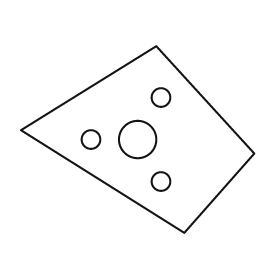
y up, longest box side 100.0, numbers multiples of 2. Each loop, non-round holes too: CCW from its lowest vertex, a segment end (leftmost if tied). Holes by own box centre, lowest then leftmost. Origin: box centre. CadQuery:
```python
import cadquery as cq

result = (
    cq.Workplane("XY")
    .moveTo(20.0, -40.0)
    .lineTo(50.0, -6.0)
    .lineTo(8.0, 40.0)
    .lineTo(-50.0, 4.0)
    .close()
    .moveTo(10.0, -18.0)
    .circle(4.0)
    .moveTo(-20.0, 0.0)
    .circle(4.0)
    .moveTo(0.0, 0.0)
    .circle(8.0)
    .moveTo(10.0, 18.0)
    .circle(4.0)
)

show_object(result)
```